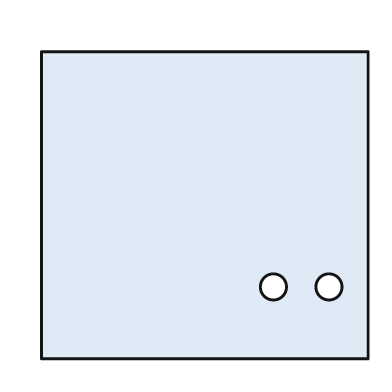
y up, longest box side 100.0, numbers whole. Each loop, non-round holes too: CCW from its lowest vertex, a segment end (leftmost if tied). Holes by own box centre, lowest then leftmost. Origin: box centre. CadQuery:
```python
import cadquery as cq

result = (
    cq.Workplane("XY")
    .moveTo(-50.0, -47.0)
    .lineTo(50.0, -47.0)
    .lineTo(50.0, 47.0)
    .lineTo(-50.0, 47.0)
    .close()
    .moveTo(21.0, -25.0)
    .circle(4.0)
    .moveTo(38.0, -25.0)
    .circle(4.0)
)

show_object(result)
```